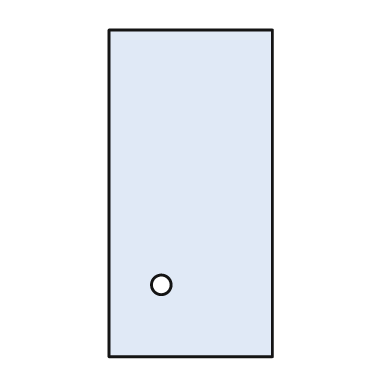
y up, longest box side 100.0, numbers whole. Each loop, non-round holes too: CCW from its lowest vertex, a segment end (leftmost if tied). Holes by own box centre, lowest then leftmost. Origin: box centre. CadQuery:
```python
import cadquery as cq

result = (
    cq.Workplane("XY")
    .moveTo(-25.0, -50.0)
    .lineTo(25.0, -50.0)
    .lineTo(25.0, 50.0)
    .lineTo(-25.0, 50.0)
    .close()
    .moveTo(-9.0, -28.0)
    .circle(3.0)
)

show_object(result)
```